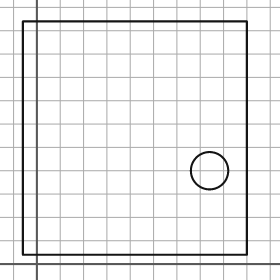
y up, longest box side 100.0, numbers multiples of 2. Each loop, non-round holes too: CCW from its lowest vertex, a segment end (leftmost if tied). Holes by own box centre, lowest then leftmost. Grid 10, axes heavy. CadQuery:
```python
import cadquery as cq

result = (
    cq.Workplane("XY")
    .moveTo(-6.0, 4.0)
    .lineTo(90.0, 4.0)
    .lineTo(90.0, 104.0)
    .lineTo(-6.0, 104.0)
    .close()
    .moveTo(74.0, 40.0)
    .circle(8.0)
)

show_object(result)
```